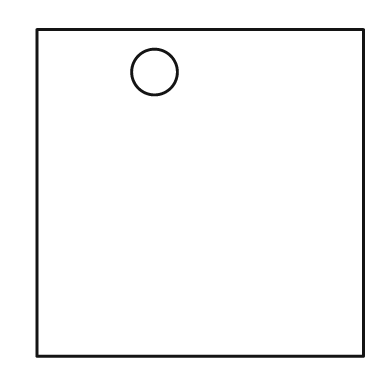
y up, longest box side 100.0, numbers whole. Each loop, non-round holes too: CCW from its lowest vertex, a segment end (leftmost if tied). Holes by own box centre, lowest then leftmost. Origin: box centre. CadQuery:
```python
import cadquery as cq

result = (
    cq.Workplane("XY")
    .moveTo(-50.0, -50.0)
    .lineTo(50.0, -50.0)
    .lineTo(50.0, 50.0)
    .lineTo(-50.0, 50.0)
    .close()
    .moveTo(-14.0, 37.0)
    .circle(7.0)
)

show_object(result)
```